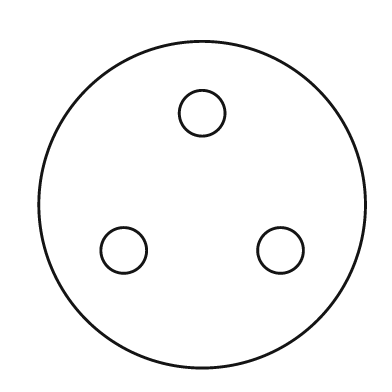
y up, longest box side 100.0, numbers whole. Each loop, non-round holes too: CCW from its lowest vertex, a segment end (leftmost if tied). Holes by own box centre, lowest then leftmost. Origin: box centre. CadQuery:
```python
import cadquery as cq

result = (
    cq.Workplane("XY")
    .moveTo(0.0, 0.0)
    .circle(50.0)
    .moveTo(-24.0, -14.0)
    .circle(7.0)
    .moveTo(24.0, -14.0)
    .circle(7.0)
    .moveTo(0.0, 28.0)
    .circle(7.0)
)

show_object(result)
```